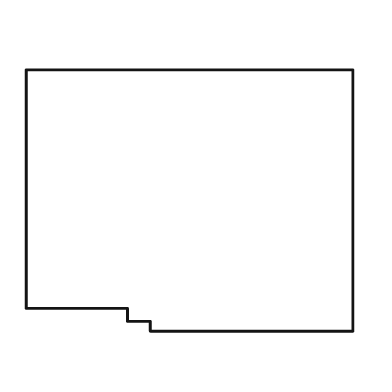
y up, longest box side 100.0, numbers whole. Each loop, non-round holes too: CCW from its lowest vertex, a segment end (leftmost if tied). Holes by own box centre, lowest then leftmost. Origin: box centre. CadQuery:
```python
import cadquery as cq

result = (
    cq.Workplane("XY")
    .moveTo(-12.0, -40.0)
    .lineTo(50.0, -40.0)
    .lineTo(50.0, 40.0)
    .lineTo(-50.0, 40.0)
    .lineTo(-50.0, -33.0)
    .lineTo(-19.0, -33.0)
    .lineTo(-19.0, -37.0)
    .lineTo(-12.0, -37.0)
    .close()
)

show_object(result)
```